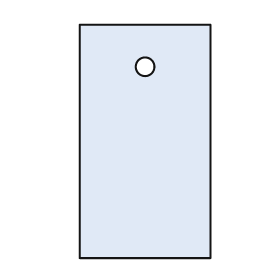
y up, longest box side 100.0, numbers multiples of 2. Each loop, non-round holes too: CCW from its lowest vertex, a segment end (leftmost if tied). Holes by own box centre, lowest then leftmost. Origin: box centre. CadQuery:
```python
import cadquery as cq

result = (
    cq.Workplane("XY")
    .moveTo(-28.0, -50.0)
    .lineTo(28.0, -50.0)
    .lineTo(28.0, 50.0)
    .lineTo(-28.0, 50.0)
    .close()
    .moveTo(0.0, 32.0)
    .circle(4.0)
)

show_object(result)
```